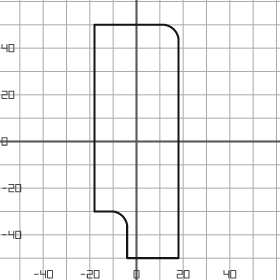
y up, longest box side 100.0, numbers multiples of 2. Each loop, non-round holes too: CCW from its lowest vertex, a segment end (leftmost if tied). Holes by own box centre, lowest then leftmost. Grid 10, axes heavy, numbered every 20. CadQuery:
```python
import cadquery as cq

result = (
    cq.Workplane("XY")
    .moveTo(-4.0, -50.0)
    .lineTo(18.0, -50.0)
    .lineTo(18.0, 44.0)
    .threePointArc((16.0, 48.0), (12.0, 50.0))
    .lineTo(-18.0, 50.0)
    .lineTo(-18.0, -30.0)
    .lineTo(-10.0, -30.0)
    .threePointArc((-6.0, -32.0), (-4.0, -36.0))
    .close()
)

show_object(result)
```